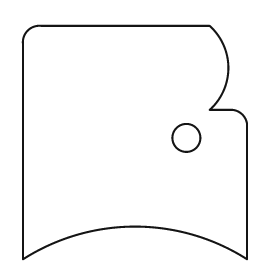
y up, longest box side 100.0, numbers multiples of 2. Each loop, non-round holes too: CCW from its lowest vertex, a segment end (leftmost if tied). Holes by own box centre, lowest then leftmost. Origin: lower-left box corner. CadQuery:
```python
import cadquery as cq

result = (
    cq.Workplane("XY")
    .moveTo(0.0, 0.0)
    .threePointArc((48.0, 14.0), (96.0, 0.0))
    .lineTo(96.0, 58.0)
    .threePointArc((94.0, 62.0), (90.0, 64.0))
    .lineTo(80.0, 64.0)
    .threePointArc((88.0, 82.0), (80.0, 100.0))
    .lineTo(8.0, 100.0)
    .threePointArc((2.0, 98.0), (0.0, 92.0))
    .close()
    .moveTo(70.0, 52.0)
    .circle(6.0)
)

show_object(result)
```